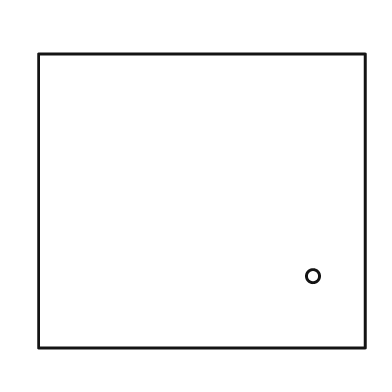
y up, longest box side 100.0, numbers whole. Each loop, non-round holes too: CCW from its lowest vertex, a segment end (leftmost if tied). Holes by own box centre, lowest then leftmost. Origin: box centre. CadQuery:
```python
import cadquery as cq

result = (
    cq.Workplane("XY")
    .moveTo(-50.0, -45.0)
    .lineTo(50.0, -45.0)
    .lineTo(50.0, 45.0)
    .lineTo(-50.0, 45.0)
    .close()
    .moveTo(34.0, -23.0)
    .circle(2.0)
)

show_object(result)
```